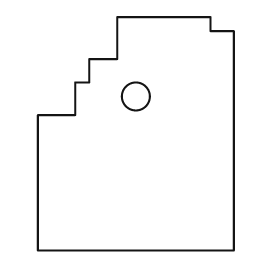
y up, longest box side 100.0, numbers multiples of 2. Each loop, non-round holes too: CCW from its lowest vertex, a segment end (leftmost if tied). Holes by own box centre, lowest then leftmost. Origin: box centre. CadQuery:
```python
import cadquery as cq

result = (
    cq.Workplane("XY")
    .moveTo(-42.0, -50.0)
    .lineTo(42.0, -50.0)
    .lineTo(42.0, 44.0)
    .lineTo(32.0, 44.0)
    .lineTo(32.0, 50.0)
    .lineTo(-8.0, 50.0)
    .lineTo(-8.0, 32.0)
    .lineTo(-20.0, 32.0)
    .lineTo(-20.0, 22.0)
    .lineTo(-26.0, 22.0)
    .lineTo(-26.0, 8.0)
    .lineTo(-42.0, 8.0)
    .close()
    .moveTo(0.0, 16.0)
    .circle(6.0)
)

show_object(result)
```